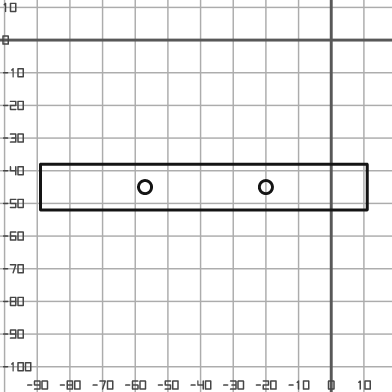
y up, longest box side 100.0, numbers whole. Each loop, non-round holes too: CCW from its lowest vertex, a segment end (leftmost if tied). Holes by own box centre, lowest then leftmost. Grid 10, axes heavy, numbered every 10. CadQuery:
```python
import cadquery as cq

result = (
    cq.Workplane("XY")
    .moveTo(-89.0, -52.0)
    .lineTo(11.0, -52.0)
    .lineTo(11.0, -38.0)
    .lineTo(-89.0, -38.0)
    .close()
    .moveTo(-57.0, -45.0)
    .circle(2.0)
    .moveTo(-20.0, -45.0)
    .circle(2.0)
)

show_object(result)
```